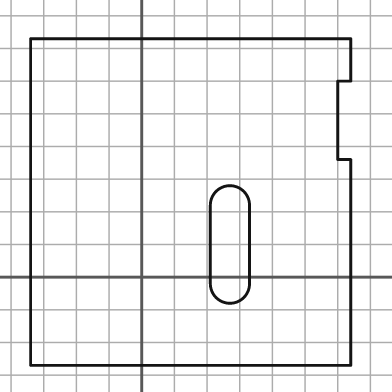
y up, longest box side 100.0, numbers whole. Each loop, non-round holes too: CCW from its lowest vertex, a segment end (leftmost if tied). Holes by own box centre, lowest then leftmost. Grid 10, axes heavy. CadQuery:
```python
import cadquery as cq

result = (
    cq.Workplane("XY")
    .moveTo(-34.0, -27.0)
    .lineTo(64.0, -27.0)
    .lineTo(64.0, 36.0)
    .lineTo(60.0, 36.0)
    .lineTo(60.0, 60.0)
    .lineTo(64.0, 60.0)
    .lineTo(64.0, 73.0)
    .lineTo(-34.0, 73.0)
    .close()
    .moveTo(21.0, -2.0)
    .threePointArc((27.0, -8.0), (33.0, -2.0))
    .lineTo(33.0, 22.0)
    .threePointArc((27.0, 28.0), (21.0, 22.0))
    .close()
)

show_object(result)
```